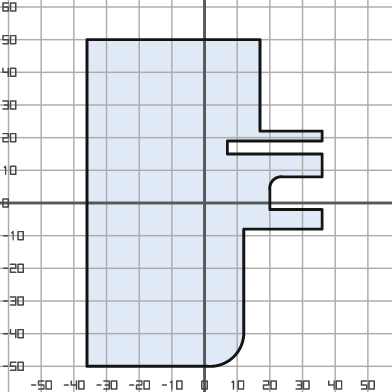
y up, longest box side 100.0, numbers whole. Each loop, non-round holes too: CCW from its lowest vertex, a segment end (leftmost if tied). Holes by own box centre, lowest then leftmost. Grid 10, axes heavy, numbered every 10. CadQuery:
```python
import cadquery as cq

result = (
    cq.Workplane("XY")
    .moveTo(-36.0, -50.0)
    .lineTo(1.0, -50.0)
    .threePointArc((9.0, -47.0), (12.0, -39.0))
    .lineTo(12.0, -8.0)
    .lineTo(36.0, -8.0)
    .lineTo(36.0, -2.0)
    .lineTo(20.0, -2.0)
    .lineTo(20.0, 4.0)
    .threePointArc((21.0, 7.0), (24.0, 8.0))
    .lineTo(36.0, 8.0)
    .lineTo(36.0, 15.0)
    .lineTo(7.0, 15.0)
    .lineTo(7.0, 19.0)
    .lineTo(36.0, 19.0)
    .lineTo(36.0, 22.0)
    .lineTo(17.0, 22.0)
    .lineTo(17.0, 50.0)
    .lineTo(-36.0, 50.0)
    .close()
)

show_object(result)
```